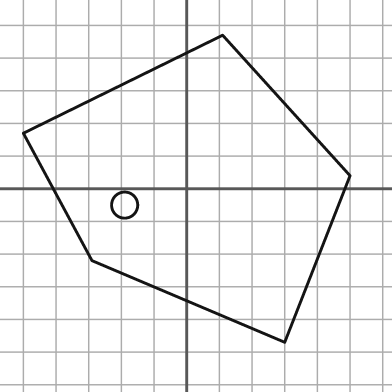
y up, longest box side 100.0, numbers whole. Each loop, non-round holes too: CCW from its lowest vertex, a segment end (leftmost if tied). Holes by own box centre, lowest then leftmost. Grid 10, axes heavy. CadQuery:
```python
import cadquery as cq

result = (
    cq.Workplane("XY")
    .moveTo(30.0, -47.0)
    .lineTo(50.0, 4.0)
    .lineTo(11.0, 47.0)
    .lineTo(-50.0, 17.0)
    .lineTo(-29.0, -22.0)
    .close()
    .moveTo(-19.0, -5.0)
    .circle(4.0)
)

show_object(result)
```